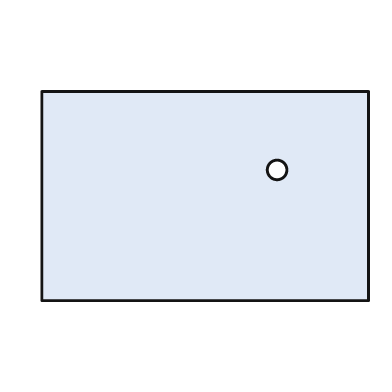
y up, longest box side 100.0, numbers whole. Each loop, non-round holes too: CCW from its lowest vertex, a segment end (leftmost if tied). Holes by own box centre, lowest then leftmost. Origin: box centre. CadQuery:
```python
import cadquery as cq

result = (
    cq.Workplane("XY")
    .moveTo(-50.0, -32.0)
    .lineTo(50.0, -32.0)
    .lineTo(50.0, 32.0)
    .lineTo(-50.0, 32.0)
    .close()
    .moveTo(22.0, 8.0)
    .circle(3.0)
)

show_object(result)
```